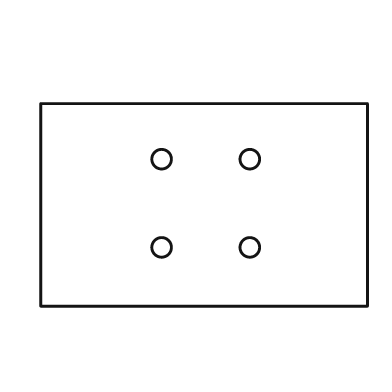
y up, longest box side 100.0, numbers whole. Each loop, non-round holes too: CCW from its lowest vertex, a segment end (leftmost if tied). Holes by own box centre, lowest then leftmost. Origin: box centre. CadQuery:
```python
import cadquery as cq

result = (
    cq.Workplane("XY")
    .moveTo(-50.0, -31.0)
    .lineTo(50.0, -31.0)
    .lineTo(50.0, 31.0)
    .lineTo(-50.0, 31.0)
    .close()
    .moveTo(-13.0, -13.0)
    .circle(3.0)
    .moveTo(14.0, -13.0)
    .circle(3.0)
    .moveTo(-13.0, 14.0)
    .circle(3.0)
    .moveTo(14.0, 14.0)
    .circle(3.0)
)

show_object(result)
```